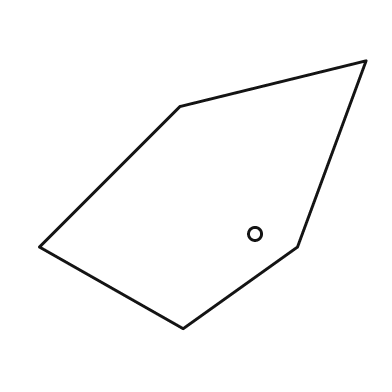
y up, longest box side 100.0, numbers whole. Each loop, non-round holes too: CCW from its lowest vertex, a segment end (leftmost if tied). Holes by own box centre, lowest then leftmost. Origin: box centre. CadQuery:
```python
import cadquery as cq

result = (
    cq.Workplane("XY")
    .moveTo(-6.0, -41.0)
    .lineTo(29.0, -16.0)
    .lineTo(50.0, 41.0)
    .lineTo(-7.0, 27.0)
    .lineTo(-50.0, -16.0)
    .close()
    .moveTo(16.0, -12.0)
    .circle(2.0)
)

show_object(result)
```